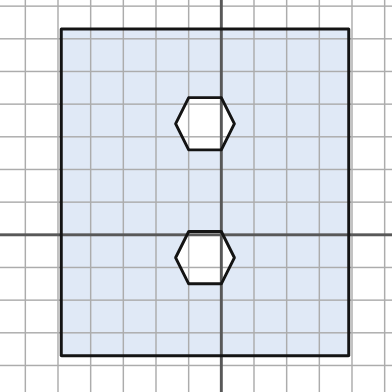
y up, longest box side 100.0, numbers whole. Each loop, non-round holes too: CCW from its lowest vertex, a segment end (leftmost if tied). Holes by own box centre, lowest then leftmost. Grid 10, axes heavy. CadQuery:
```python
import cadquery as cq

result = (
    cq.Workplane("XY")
    .moveTo(-49.0, -37.0)
    .lineTo(39.0, -37.0)
    .lineTo(39.0, 63.0)
    .lineTo(-49.0, 63.0)
    .close()
    .moveTo(-10.0, -15.0)
    .lineTo(0.0, -15.0)
    .lineTo(4.0, -7.0)
    .lineTo(0.0, 1.0)
    .lineTo(-10.0, 1.0)
    .lineTo(-14.0, -7.0)
    .close()
    .moveTo(-10.0, 26.0)
    .lineTo(0.0, 26.0)
    .lineTo(4.0, 34.0)
    .lineTo(0.0, 42.0)
    .lineTo(-10.0, 42.0)
    .lineTo(-14.0, 34.0)
    .close()
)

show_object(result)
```